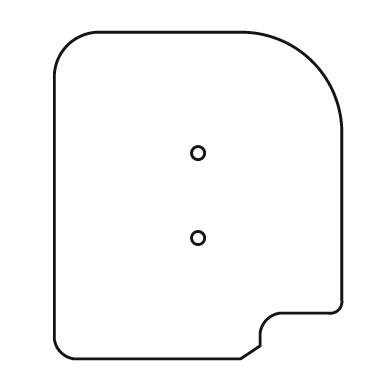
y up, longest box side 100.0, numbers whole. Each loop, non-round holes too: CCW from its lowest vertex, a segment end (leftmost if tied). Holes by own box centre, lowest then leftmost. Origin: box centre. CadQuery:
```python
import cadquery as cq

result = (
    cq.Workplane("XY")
    .moveTo(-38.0, -50.0)
    .lineTo(13.0, -50.0)
    .lineTo(19.0, -46.0)
    .lineTo(19.0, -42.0)
    .threePointArc((21.0, -38.0), (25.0, -36.0))
    .lineTo(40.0, -36.0)
    .threePointArc((43.0, -35.0), (44.0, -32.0))
    .lineTo(44.0, 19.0)
    .threePointArc((35.0, 41.0), (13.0, 50.0))
    .lineTo(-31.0, 50.0)
    .threePointArc((-40.0, 46.0), (-44.0, 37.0))
    .lineTo(-44.0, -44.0)
    .threePointArc((-42.0, -48.0), (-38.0, -50.0))
    .close()
    .moveTo(0.0, -13.0)
    .circle(2.0)
    .moveTo(0.0, 13.0)
    .circle(2.0)
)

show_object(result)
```